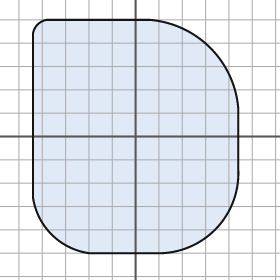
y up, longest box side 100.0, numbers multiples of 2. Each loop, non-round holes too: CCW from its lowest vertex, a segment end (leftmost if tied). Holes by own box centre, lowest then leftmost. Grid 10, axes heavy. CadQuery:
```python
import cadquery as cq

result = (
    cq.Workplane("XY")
    .moveTo(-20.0, -50.0)
    .lineTo(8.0, -50.0)
    .threePointArc((34.0, -40.0), (44.0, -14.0))
    .lineTo(44.0, 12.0)
    .threePointArc((32.0, 38.0), (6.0, 50.0))
    .lineTo(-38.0, 50.0)
    .threePointArc((-42.0, 48.0), (-44.0, 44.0))
    .lineTo(-44.0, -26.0)
    .threePointArc((-36.0, -42.0), (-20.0, -50.0))
    .close()
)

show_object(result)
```